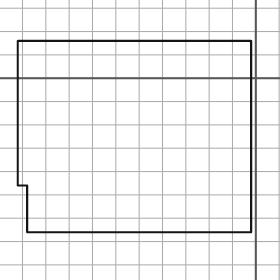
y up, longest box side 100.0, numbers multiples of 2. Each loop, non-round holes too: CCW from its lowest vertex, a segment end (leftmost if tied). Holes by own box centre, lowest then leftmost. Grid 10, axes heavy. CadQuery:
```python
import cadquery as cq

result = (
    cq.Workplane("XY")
    .moveTo(-98.0, -66.0)
    .lineTo(-2.0, -66.0)
    .lineTo(-2.0, 16.0)
    .lineTo(-102.0, 16.0)
    .lineTo(-102.0, -46.0)
    .lineTo(-98.0, -46.0)
    .close()
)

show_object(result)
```